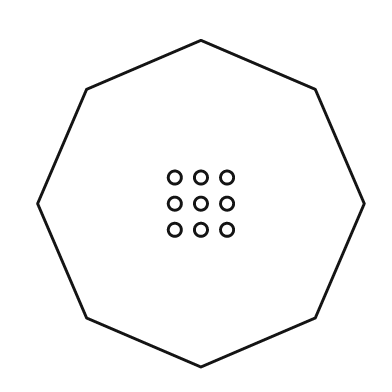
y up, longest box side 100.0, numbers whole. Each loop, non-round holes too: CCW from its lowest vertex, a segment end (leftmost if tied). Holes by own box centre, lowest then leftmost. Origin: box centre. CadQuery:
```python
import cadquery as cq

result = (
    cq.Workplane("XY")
    .moveTo(0.0, -50.0)
    .lineTo(35.0, -35.0)
    .lineTo(50.0, 0.0)
    .lineTo(35.0, 35.0)
    .lineTo(0.0, 50.0)
    .lineTo(-35.0, 35.0)
    .lineTo(-50.0, 0.0)
    .lineTo(-35.0, -35.0)
    .close()
    .moveTo(-8.0, -8.0)
    .circle(2.0)
    .moveTo(0.0, -8.0)
    .circle(2.0)
    .moveTo(8.0, -8.0)
    .circle(2.0)
    .moveTo(-8.0, 0.0)
    .circle(2.0)
    .moveTo(0.0, 0.0)
    .circle(2.0)
    .moveTo(8.0, 0.0)
    .circle(2.0)
    .moveTo(-8.0, 8.0)
    .circle(2.0)
    .moveTo(0.0, 8.0)
    .circle(2.0)
    .moveTo(8.0, 8.0)
    .circle(2.0)
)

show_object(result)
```